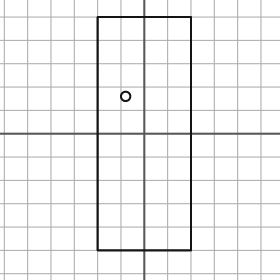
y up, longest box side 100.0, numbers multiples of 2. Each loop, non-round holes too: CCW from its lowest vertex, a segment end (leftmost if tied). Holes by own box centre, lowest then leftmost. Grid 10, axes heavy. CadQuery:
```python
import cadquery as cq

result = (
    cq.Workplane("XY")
    .moveTo(-20.0, -50.0)
    .lineTo(20.0, -50.0)
    .lineTo(20.0, 50.0)
    .lineTo(-20.0, 50.0)
    .close()
    .moveTo(-8.0, 16.0)
    .circle(2.0)
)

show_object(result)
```